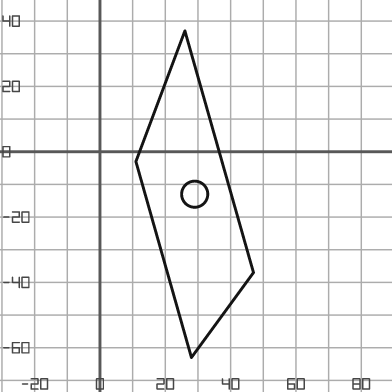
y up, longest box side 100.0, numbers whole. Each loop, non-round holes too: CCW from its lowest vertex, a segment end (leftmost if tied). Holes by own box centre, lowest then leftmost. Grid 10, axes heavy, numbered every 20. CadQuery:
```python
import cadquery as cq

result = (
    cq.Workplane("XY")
    .moveTo(28.0, -63.0)
    .lineTo(47.0, -37.0)
    .lineTo(26.0, 37.0)
    .lineTo(11.0, -3.0)
    .close()
    .moveTo(29.0, -13.0)
    .circle(4.0)
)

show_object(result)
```